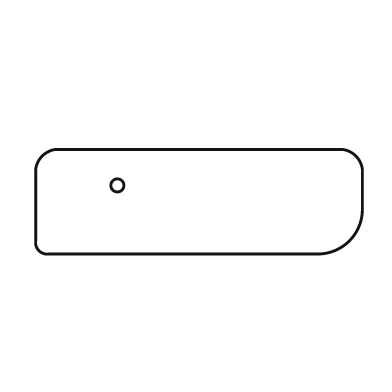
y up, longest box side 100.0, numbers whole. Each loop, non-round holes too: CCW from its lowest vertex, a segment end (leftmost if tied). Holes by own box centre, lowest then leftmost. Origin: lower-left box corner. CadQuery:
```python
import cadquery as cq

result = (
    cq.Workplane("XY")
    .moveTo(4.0, 0.0)
    .lineTo(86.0, 0.0)
    .threePointArc((96.0, 4.0), (100.0, 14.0))
    .lineTo(100.0, 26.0)
    .threePointArc((98.0, 30.0), (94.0, 32.0))
    .lineTo(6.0, 32.0)
    .threePointArc((2.0, 30.0), (0.0, 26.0))
    .lineTo(0.0, 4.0)
    .threePointArc((1.0, 1.0), (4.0, 0.0))
    .close()
    .moveTo(25.0, 21.0)
    .circle(2.0)
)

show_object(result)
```